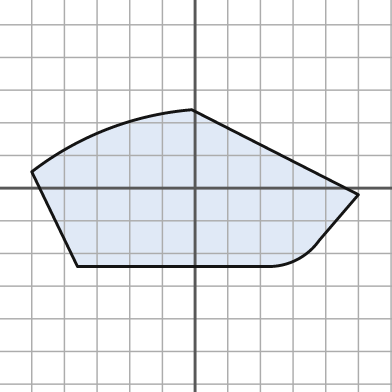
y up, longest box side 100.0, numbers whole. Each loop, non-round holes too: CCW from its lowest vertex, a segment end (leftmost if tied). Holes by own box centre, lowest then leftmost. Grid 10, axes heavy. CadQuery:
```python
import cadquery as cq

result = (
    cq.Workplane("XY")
    .moveTo(-36.0, -24.0)
    .lineTo(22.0, -24.0)
    .threePointArc((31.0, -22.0), (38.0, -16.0))
    .lineTo(50.0, -2.0)
    .lineTo(-1.0, 24.0)
    .threePointArc((-27.0, 18.0), (-50.0, 5.0))
    .close()
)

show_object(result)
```